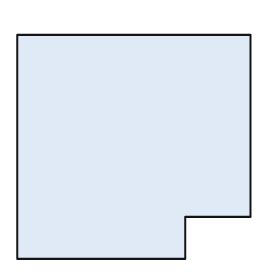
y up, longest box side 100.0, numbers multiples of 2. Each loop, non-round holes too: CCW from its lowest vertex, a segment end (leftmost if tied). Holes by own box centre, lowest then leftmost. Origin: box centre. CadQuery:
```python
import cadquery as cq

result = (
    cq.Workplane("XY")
    .moveTo(-50.0, -48.0)
    .lineTo(22.0, -48.0)
    .lineTo(22.0, -30.0)
    .lineTo(50.0, -30.0)
    .lineTo(50.0, 48.0)
    .lineTo(-50.0, 48.0)
    .close()
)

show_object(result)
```